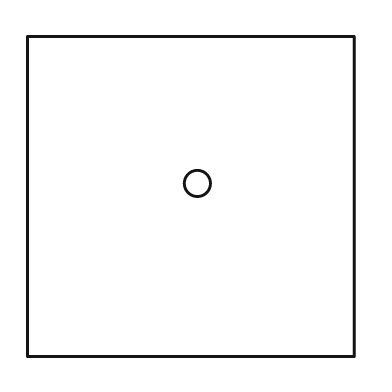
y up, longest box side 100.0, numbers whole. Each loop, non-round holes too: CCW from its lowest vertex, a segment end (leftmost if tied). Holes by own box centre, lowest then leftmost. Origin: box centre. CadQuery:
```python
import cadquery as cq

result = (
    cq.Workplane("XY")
    .moveTo(-50.0, -49.0)
    .lineTo(50.0, -49.0)
    .lineTo(50.0, 49.0)
    .lineTo(-50.0, 49.0)
    .close()
    .moveTo(2.0, 4.0)
    .circle(4.0)
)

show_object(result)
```